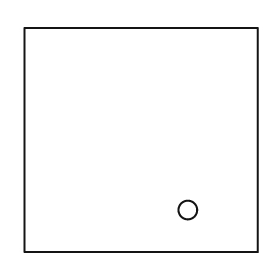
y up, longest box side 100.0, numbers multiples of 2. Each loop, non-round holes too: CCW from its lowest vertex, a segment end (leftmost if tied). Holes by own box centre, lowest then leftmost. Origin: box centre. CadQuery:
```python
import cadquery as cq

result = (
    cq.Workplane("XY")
    .moveTo(-50.0, -48.0)
    .lineTo(50.0, -48.0)
    .lineTo(50.0, 48.0)
    .lineTo(-50.0, 48.0)
    .close()
    .moveTo(20.0, -30.0)
    .circle(4.0)
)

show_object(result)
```